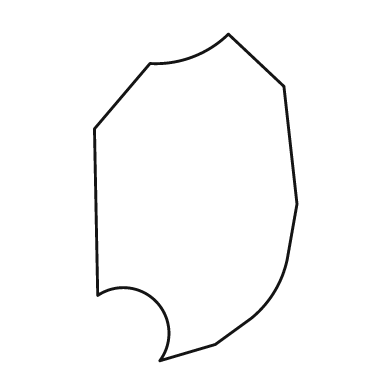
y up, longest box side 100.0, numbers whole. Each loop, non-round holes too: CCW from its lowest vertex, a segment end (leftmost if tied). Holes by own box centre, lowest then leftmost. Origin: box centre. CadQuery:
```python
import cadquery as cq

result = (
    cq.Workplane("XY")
    .moveTo(-11.0, -50.0)
    .lineTo(6.0, -45.0)
    .lineTo(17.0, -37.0)
    .threePointArc((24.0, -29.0), (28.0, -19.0))
    .lineTo(31.0, -2.0)
    .lineTo(27.0, 34.0)
    .lineTo(10.0, 50.0)
    .threePointArc((-1.0, 43.0), (-14.0, 41.0))
    .lineTo(-31.0, 21.0)
    .lineTo(-30.0, -30.0)
    .threePointArc((-12.0, -32.0), (-11.0, -50.0))
    .close()
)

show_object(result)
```